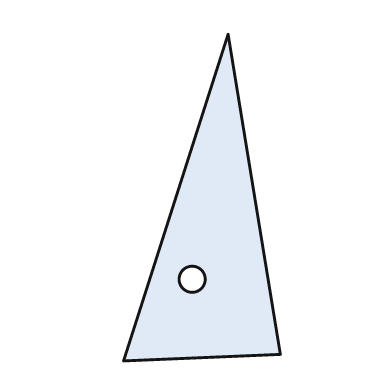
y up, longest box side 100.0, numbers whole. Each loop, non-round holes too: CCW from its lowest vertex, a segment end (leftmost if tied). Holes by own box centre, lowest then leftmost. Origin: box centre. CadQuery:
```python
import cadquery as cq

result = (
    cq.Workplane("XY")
    .moveTo(-24.0, -50.0)
    .lineTo(24.0, -48.0)
    .lineTo(8.0, 50.0)
    .close()
    .moveTo(-3.0, -25.0)
    .circle(4.0)
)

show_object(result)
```